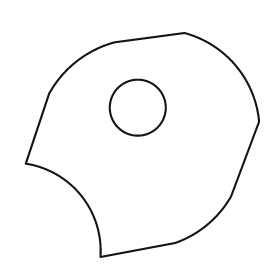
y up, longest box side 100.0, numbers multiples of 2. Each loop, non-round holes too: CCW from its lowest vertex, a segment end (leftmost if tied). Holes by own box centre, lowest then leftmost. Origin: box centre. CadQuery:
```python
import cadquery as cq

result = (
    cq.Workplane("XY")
    .moveTo(-18.0, -48.0)
    .lineTo(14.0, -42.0)
    .threePointArc((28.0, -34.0), (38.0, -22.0))
    .lineTo(50.0, 10.0)
    .threePointArc((40.0, 34.0), (18.0, 48.0))
    .lineTo(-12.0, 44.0)
    .threePointArc((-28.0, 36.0), (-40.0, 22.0))
    .lineTo(-50.0, -8.0)
    .threePointArc((-26.0, -22.0), (-18.0, -48.0))
    .close()
    .moveTo(-2.0, 16.0)
    .circle(12.0)
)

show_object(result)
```